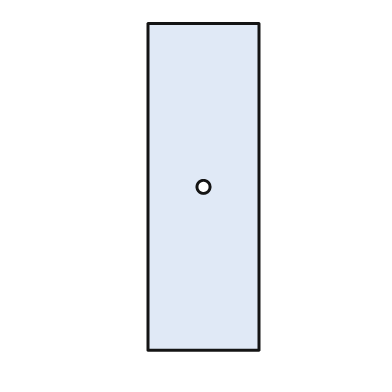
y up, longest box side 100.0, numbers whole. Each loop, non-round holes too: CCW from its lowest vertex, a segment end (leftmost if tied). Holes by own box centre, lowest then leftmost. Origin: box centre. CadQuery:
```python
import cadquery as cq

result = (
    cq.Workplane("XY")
    .moveTo(-17.0, -50.0)
    .lineTo(17.0, -50.0)
    .lineTo(17.0, 50.0)
    .lineTo(-17.0, 50.0)
    .close()
    .moveTo(0.0, 0.0)
    .circle(2.0)
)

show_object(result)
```